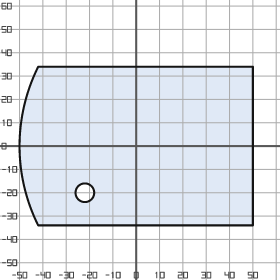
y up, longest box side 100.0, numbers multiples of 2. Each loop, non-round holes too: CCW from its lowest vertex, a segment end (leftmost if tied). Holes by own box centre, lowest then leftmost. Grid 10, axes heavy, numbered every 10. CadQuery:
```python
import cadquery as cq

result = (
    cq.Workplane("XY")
    .moveTo(-42.0, -34.0)
    .lineTo(50.0, -34.0)
    .lineTo(50.0, 34.0)
    .lineTo(-42.0, 34.0)
    .threePointArc((-50.0, 0.0), (-42.0, -34.0))
    .close()
    .moveTo(-22.0, -20.0)
    .circle(4.0)
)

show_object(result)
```